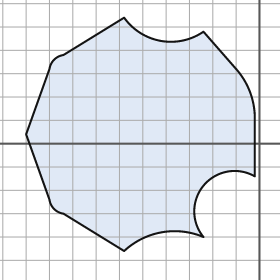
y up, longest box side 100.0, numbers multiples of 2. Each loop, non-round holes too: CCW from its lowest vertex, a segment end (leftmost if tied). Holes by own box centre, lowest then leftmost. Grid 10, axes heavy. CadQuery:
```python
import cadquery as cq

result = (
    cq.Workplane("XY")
    .moveTo(-58.0, -46.0)
    .threePointArc((-42.0, -38.0), (-24.0, -40.0))
    .threePointArc((-24.0, -18.0), (-2.0, -14.0))
    .lineTo(-2.0, 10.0)
    .threePointArc((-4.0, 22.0), (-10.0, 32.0))
    .lineTo(-24.0, 48.0)
    .threePointArc((-42.0, 44.0), (-58.0, 54.0))
    .lineTo(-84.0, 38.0)
    .threePointArc((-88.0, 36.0), (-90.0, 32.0))
    .lineTo(-100.0, 4.0)
    .lineTo(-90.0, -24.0)
    .threePointArc((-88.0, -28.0), (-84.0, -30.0))
    .close()
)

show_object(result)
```